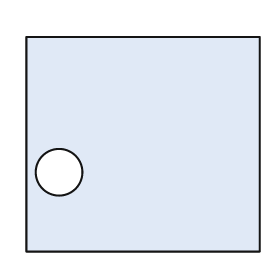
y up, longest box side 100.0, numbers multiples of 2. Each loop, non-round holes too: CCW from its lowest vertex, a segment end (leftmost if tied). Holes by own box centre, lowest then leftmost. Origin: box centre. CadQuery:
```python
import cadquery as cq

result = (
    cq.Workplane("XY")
    .moveTo(-50.0, -46.0)
    .lineTo(50.0, -46.0)
    .lineTo(50.0, 46.0)
    .lineTo(-50.0, 46.0)
    .close()
    .moveTo(-36.0, -12.0)
    .circle(10.0)
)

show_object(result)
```